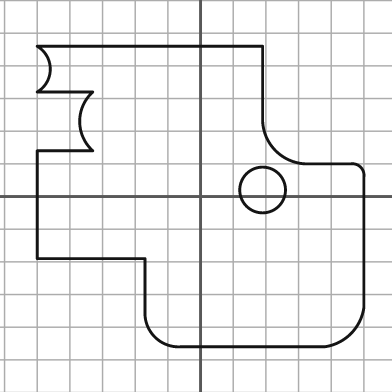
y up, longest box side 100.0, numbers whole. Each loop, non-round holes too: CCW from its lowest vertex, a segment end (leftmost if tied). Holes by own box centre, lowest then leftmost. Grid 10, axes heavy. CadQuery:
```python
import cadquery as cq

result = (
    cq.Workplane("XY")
    .moveTo(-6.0, -46.0)
    .lineTo(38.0, -46.0)
    .threePointArc((46.0, -42.0), (50.0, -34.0))
    .lineTo(50.0, 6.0)
    .threePointArc((49.0, 9.0), (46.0, 10.0))
    .lineTo(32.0, 10.0)
    .threePointArc((23.0, 14.0), (19.0, 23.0))
    .lineTo(19.0, 46.0)
    .lineTo(-50.0, 46.0)
    .threePointArc((-46.0, 39.0), (-50.0, 32.0))
    .lineTo(-33.0, 32.0)
    .threePointArc((-37.0, 23.0), (-33.0, 14.0))
    .lineTo(-50.0, 14.0)
    .lineTo(-50.0, -19.0)
    .lineTo(-17.0, -19.0)
    .lineTo(-17.0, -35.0)
    .threePointArc((-14.0, -43.0), (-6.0, -46.0))
    .close()
    .moveTo(19.0, 2.0)
    .circle(7.0)
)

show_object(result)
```